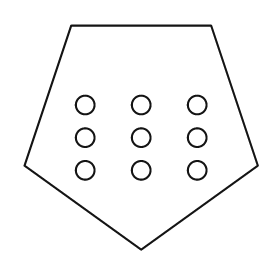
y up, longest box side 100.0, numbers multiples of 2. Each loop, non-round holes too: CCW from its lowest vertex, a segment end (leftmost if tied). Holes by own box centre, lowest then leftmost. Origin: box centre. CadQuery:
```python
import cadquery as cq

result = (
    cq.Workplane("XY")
    .moveTo(0.0, -48.0)
    .lineTo(50.0, -12.0)
    .lineTo(30.0, 48.0)
    .lineTo(-30.0, 48.0)
    .lineTo(-50.0, -12.0)
    .close()
    .moveTo(-24.0, -14.0)
    .circle(4.0)
    .moveTo(0.0, -14.0)
    .circle(4.0)
    .moveTo(24.0, -14.0)
    .circle(4.0)
    .moveTo(-24.0, 0.0)
    .circle(4.0)
    .moveTo(0.0, 0.0)
    .circle(4.0)
    .moveTo(24.0, 0.0)
    .circle(4.0)
    .moveTo(-24.0, 14.0)
    .circle(4.0)
    .moveTo(0.0, 14.0)
    .circle(4.0)
    .moveTo(24.0, 14.0)
    .circle(4.0)
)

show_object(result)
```